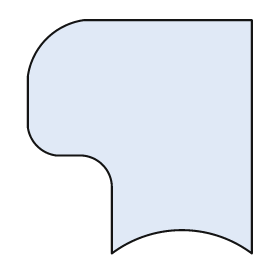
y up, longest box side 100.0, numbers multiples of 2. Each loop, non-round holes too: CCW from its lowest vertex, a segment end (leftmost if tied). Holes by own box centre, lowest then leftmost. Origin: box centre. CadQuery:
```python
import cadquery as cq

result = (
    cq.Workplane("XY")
    .moveTo(-12.0, -50.0)
    .threePointArc((18.0, -40.0), (48.0, -50.0))
    .lineTo(48.0, 50.0)
    .lineTo(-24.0, 50.0)
    .threePointArc((-40.0, 42.0), (-48.0, 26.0))
    .lineTo(-48.0, 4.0)
    .threePointArc((-44.0, -4.0), (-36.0, -8.0))
    .lineTo(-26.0, -8.0)
    .threePointArc((-16.0, -12.0), (-12.0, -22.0))
    .close()
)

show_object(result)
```